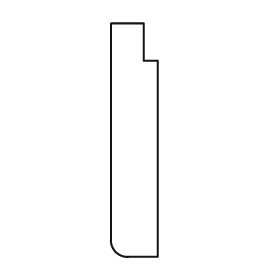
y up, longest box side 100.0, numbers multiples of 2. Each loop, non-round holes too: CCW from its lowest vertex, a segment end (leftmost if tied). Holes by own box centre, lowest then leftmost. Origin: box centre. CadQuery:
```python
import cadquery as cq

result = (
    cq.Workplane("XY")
    .moveTo(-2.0, -50.0)
    .lineTo(10.0, -50.0)
    .lineTo(10.0, 34.0)
    .lineTo(4.0, 34.0)
    .lineTo(4.0, 50.0)
    .lineTo(-10.0, 50.0)
    .lineTo(-10.0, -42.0)
    .threePointArc((-8.0, -48.0), (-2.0, -50.0))
    .close()
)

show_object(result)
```